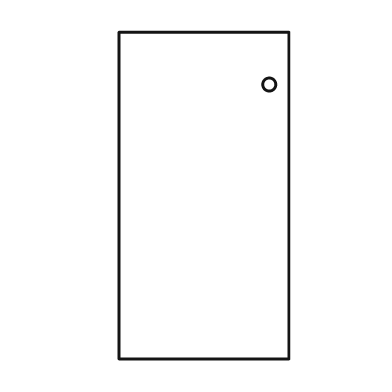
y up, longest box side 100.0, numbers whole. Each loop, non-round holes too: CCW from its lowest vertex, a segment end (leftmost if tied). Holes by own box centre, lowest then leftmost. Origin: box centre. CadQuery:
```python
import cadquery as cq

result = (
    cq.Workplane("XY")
    .moveTo(-26.0, -50.0)
    .lineTo(26.0, -50.0)
    .lineTo(26.0, 50.0)
    .lineTo(-26.0, 50.0)
    .close()
    .moveTo(20.0, 34.0)
    .circle(2.0)
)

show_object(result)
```